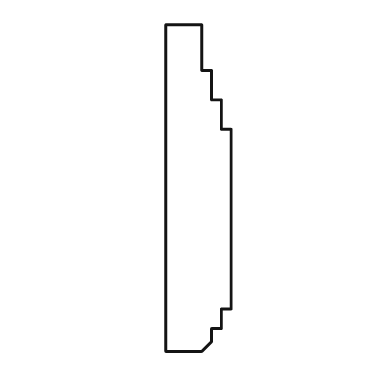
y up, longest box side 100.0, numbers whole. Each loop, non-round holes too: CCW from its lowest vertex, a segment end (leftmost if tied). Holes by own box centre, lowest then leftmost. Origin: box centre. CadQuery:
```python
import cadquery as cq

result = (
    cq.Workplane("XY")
    .moveTo(-10.0, -50.0)
    .lineTo(1.0, -50.0)
    .lineTo(4.0, -47.0)
    .lineTo(4.0, -43.0)
    .lineTo(7.0, -43.0)
    .lineTo(7.0, -37.0)
    .lineTo(10.0, -37.0)
    .lineTo(10.0, 18.0)
    .lineTo(7.0, 18.0)
    .lineTo(7.0, 27.0)
    .lineTo(4.0, 27.0)
    .lineTo(4.0, 36.0)
    .lineTo(1.0, 36.0)
    .lineTo(1.0, 50.0)
    .lineTo(-10.0, 50.0)
    .close()
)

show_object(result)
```